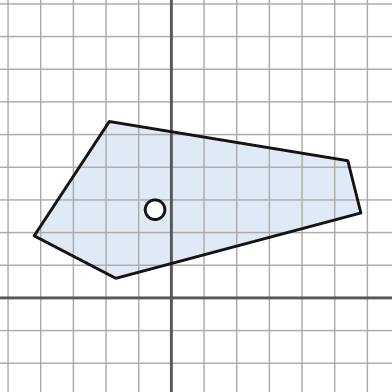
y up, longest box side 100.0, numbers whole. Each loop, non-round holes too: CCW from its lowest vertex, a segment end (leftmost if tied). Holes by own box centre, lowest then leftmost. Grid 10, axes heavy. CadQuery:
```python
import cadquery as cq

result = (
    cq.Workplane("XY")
    .moveTo(-17.0, 6.0)
    .lineTo(58.0, 26.0)
    .lineTo(54.0, 42.0)
    .lineTo(-19.0, 54.0)
    .lineTo(-42.0, 19.0)
    .close()
    .moveTo(-5.0, 27.0)
    .circle(3.0)
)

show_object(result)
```